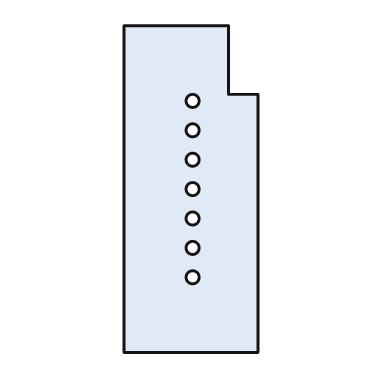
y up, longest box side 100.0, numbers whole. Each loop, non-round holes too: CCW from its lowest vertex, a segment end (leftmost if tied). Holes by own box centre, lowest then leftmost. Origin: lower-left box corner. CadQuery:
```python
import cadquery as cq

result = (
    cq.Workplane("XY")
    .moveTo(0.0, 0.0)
    .lineTo(41.0, 0.0)
    .lineTo(41.0, 79.0)
    .lineTo(32.0, 79.0)
    .lineTo(32.0, 100.0)
    .lineTo(0.0, 100.0)
    .close()
    .moveTo(21.0, 23.0)
    .circle(2.0)
    .moveTo(21.0, 32.0)
    .circle(2.0)
    .moveTo(21.0, 41.0)
    .circle(2.0)
    .moveTo(21.0, 50.0)
    .circle(2.0)
    .moveTo(21.0, 59.0)
    .circle(2.0)
    .moveTo(21.0, 68.0)
    .circle(2.0)
    .moveTo(21.0, 77.0)
    .circle(2.0)
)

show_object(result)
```